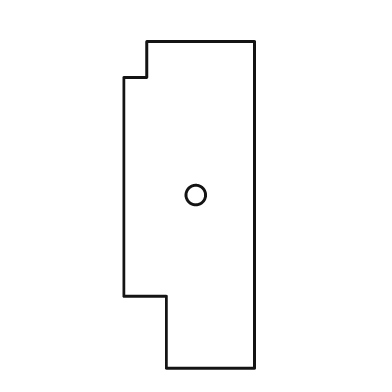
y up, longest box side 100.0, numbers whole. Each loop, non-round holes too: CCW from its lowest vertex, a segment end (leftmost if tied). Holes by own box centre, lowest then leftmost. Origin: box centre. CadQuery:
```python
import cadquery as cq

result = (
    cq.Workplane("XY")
    .moveTo(-7.0, -50.0)
    .lineTo(20.0, -50.0)
    .lineTo(20.0, 50.0)
    .lineTo(-13.0, 50.0)
    .lineTo(-13.0, 39.0)
    .lineTo(-20.0, 39.0)
    .lineTo(-20.0, -28.0)
    .lineTo(-7.0, -28.0)
    .close()
    .moveTo(2.0, 3.0)
    .circle(3.0)
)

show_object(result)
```